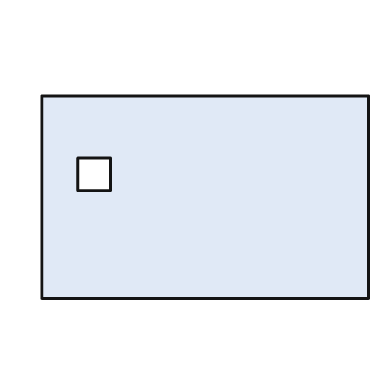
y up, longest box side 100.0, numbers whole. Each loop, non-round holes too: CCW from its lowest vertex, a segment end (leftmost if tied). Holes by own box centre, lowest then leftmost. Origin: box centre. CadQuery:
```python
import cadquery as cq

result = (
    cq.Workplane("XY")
    .moveTo(-50.0, -31.0)
    .lineTo(50.0, -31.0)
    .lineTo(50.0, 31.0)
    .lineTo(-50.0, 31.0)
    .close()
    .moveTo(-39.0, 2.0)
    .lineTo(-29.0, 2.0)
    .lineTo(-29.0, 12.0)
    .lineTo(-39.0, 12.0)
    .close()
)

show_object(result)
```